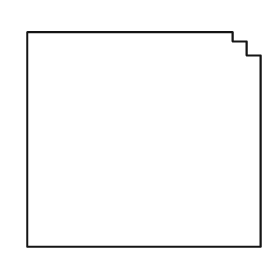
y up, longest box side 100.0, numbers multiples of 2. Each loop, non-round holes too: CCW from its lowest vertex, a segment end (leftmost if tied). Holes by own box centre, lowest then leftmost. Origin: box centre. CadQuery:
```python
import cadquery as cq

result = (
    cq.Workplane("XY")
    .moveTo(-50.0, -46.0)
    .lineTo(50.0, -46.0)
    .lineTo(50.0, 36.0)
    .lineTo(44.0, 36.0)
    .lineTo(44.0, 42.0)
    .lineTo(38.0, 42.0)
    .lineTo(38.0, 46.0)
    .lineTo(-50.0, 46.0)
    .close()
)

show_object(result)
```